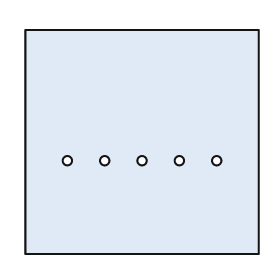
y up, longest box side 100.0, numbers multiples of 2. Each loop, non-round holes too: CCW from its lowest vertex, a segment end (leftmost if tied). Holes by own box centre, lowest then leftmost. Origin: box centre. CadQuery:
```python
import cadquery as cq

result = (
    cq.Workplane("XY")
    .moveTo(-50.0, -48.0)
    .lineTo(50.0, -48.0)
    .lineTo(50.0, 48.0)
    .lineTo(-50.0, 48.0)
    .close()
    .moveTo(-32.0, -8.0)
    .circle(2.0)
    .moveTo(-16.0, -8.0)
    .circle(2.0)
    .moveTo(0.0, -8.0)
    .circle(2.0)
    .moveTo(16.0, -8.0)
    .circle(2.0)
    .moveTo(32.0, -8.0)
    .circle(2.0)
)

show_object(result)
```